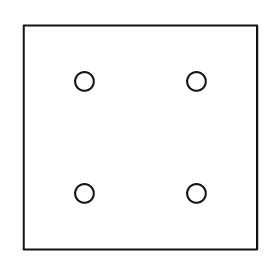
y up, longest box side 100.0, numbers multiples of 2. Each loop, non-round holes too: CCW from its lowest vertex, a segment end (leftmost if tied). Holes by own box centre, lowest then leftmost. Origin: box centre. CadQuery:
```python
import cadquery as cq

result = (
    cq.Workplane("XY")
    .moveTo(-50.0, -48.0)
    .lineTo(50.0, -48.0)
    .lineTo(50.0, 48.0)
    .lineTo(-50.0, 48.0)
    .close()
    .moveTo(-24.0, -24.0)
    .circle(4.0)
    .moveTo(24.0, -24.0)
    .circle(4.0)
    .moveTo(-24.0, 24.0)
    .circle(4.0)
    .moveTo(24.0, 24.0)
    .circle(4.0)
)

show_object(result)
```